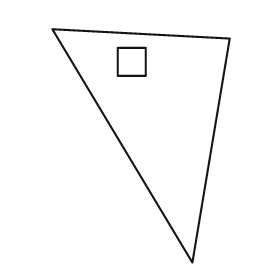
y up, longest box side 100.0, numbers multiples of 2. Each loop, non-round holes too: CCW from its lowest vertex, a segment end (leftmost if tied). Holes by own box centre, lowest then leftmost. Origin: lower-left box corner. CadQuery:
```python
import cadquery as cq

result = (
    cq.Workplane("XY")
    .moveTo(60.0, 0.0)
    .lineTo(76.0, 96.0)
    .lineTo(0.0, 100.0)
    .close()
    .moveTo(28.0, 80.0)
    .lineTo(40.0, 80.0)
    .lineTo(40.0, 92.0)
    .lineTo(28.0, 92.0)
    .close()
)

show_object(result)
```